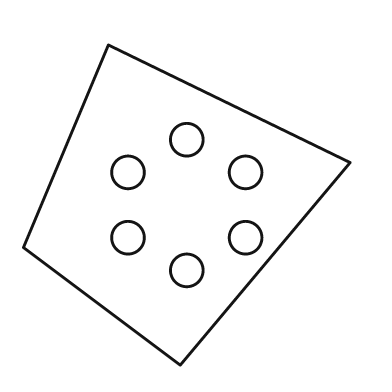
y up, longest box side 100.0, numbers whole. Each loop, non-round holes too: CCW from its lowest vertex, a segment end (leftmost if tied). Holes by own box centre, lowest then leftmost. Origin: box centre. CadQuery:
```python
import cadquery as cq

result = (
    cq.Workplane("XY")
    .moveTo(-2.0, -49.0)
    .lineTo(50.0, 13.0)
    .lineTo(-24.0, 49.0)
    .lineTo(-50.0, -13.0)
    .close()
    .moveTo(0.0, -20.0)
    .circle(5.0)
    .moveTo(-18.0, -10.0)
    .circle(5.0)
    .moveTo(18.0, -10.0)
    .circle(5.0)
    .moveTo(-18.0, 10.0)
    .circle(5.0)
    .moveTo(18.0, 10.0)
    .circle(5.0)
    .moveTo(0.0, 20.0)
    .circle(5.0)
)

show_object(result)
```